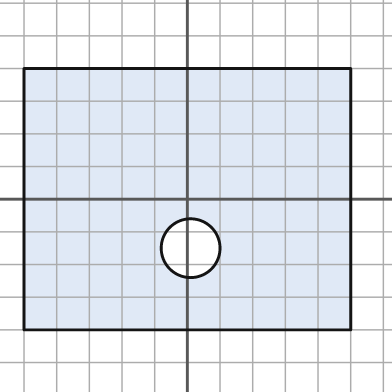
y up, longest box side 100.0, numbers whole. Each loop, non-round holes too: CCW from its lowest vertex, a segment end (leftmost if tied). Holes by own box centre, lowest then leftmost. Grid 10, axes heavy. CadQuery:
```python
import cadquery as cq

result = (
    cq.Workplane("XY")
    .moveTo(-50.0, -40.0)
    .lineTo(50.0, -40.0)
    .lineTo(50.0, 40.0)
    .lineTo(-50.0, 40.0)
    .close()
    .moveTo(1.0, -15.0)
    .circle(9.0)
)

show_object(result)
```